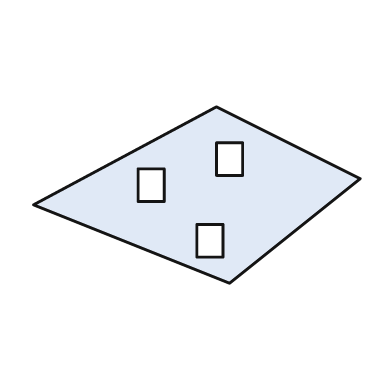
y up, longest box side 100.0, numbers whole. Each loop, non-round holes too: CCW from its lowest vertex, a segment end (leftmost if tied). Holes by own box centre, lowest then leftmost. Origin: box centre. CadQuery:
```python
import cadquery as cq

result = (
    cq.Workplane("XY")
    .moveTo(10.0, -27.0)
    .lineTo(50.0, 5.0)
    .lineTo(6.0, 27.0)
    .lineTo(-50.0, -3.0)
    .close()
    .moveTo(0.0, -19.0)
    .lineTo(8.0, -19.0)
    .lineTo(8.0, -9.0)
    .lineTo(0.0, -9.0)
    .close()
    .moveTo(-18.0, -2.0)
    .lineTo(-10.0, -2.0)
    .lineTo(-10.0, 8.0)
    .lineTo(-18.0, 8.0)
    .close()
    .moveTo(6.0, 6.0)
    .lineTo(14.0, 6.0)
    .lineTo(14.0, 16.0)
    .lineTo(6.0, 16.0)
    .close()
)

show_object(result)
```